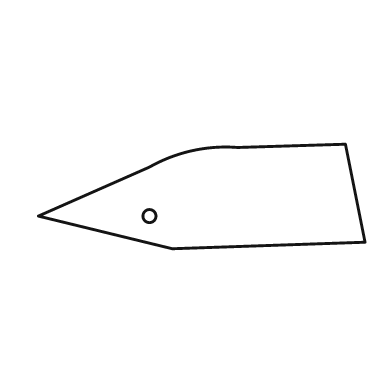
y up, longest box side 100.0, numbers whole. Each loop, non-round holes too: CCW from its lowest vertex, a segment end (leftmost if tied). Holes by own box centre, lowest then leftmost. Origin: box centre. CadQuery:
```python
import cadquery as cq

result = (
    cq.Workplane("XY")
    .moveTo(-9.0, -16.0)
    .lineTo(50.0, -14.0)
    .lineTo(44.0, 16.0)
    .lineTo(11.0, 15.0)
    .threePointArc((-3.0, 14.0), (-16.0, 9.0))
    .lineTo(-50.0, -6.0)
    .close()
    .moveTo(-16.0, -6.0)
    .circle(2.0)
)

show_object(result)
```